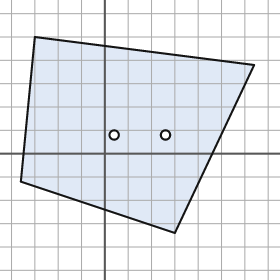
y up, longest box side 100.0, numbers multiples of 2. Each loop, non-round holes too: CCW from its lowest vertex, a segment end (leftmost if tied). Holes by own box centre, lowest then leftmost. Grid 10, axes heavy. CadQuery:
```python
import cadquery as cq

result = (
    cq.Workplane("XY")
    .moveTo(30.0, -34.0)
    .lineTo(64.0, 38.0)
    .lineTo(-30.0, 50.0)
    .lineTo(-36.0, -12.0)
    .close()
    .moveTo(4.0, 8.0)
    .circle(2.0)
    .moveTo(26.0, 8.0)
    .circle(2.0)
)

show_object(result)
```